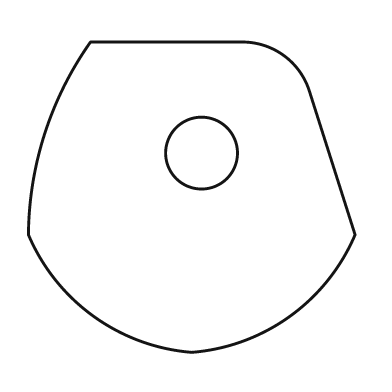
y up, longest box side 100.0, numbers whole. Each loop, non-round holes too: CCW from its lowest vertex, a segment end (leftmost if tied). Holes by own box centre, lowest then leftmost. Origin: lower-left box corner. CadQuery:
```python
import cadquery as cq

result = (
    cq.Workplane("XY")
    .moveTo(50.0, 0.0)
    .threePointArc((80.0, 11.0), (100.0, 36.0))
    .lineTo(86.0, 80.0)
    .threePointArc((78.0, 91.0), (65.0, 95.0))
    .lineTo(19.0, 95.0)
    .threePointArc((5.0, 67.0), (0.0, 36.0))
    .threePointArc((20.0, 11.0), (50.0, 0.0))
    .close()
    .moveTo(53.0, 61.0)
    .circle(11.0)
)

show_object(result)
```